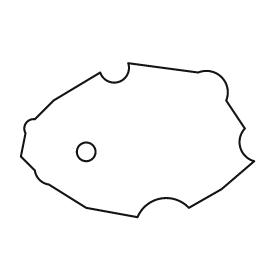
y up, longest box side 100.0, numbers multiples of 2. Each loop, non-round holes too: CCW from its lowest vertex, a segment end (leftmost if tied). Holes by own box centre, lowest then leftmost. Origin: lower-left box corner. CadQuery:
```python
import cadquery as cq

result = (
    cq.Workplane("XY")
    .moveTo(50.0, 0.0)
    .threePointArc((60.0, 8.0), (72.0, 4.0))
    .lineTo(86.0, 12.0)
    .lineTo(100.0, 24.0)
    .threePointArc((94.0, 30.0), (96.0, 38.0))
    .lineTo(88.0, 50.0)
    .threePointArc((86.0, 60.0), (76.0, 62.0))
    .lineTo(46.0, 66.0)
    .threePointArc((42.0, 58.0), (34.0, 62.0))
    .lineTo(14.0, 50.0)
    .lineTo(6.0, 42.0)
    .threePointArc((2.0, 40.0), (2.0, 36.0))
    .lineTo(0.0, 26.0)
    .lineTo(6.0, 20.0)
    .threePointArc((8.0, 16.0), (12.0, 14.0))
    .lineTo(28.0, 4.0)
    .close()
    .moveTo(28.0, 28.0)
    .circle(4.0)
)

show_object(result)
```